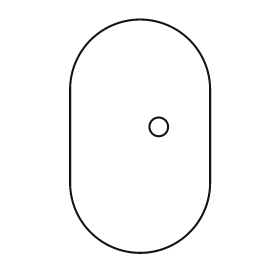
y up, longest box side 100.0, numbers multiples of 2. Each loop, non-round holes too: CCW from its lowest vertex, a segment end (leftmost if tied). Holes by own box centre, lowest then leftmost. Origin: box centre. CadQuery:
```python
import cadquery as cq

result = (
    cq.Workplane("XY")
    .moveTo(-30.0, -20.0)
    .threePointArc((0.0, -50.0), (30.0, -20.0))
    .lineTo(30.0, 20.0)
    .threePointArc((0.0, 50.0), (-30.0, 20.0))
    .close()
    .moveTo(8.0, 4.0)
    .circle(4.0)
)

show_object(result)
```